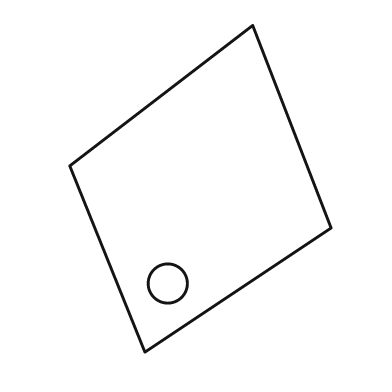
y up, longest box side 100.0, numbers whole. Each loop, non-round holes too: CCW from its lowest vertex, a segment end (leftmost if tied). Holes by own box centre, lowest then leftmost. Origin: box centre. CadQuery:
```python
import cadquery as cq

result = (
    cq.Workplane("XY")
    .moveTo(-17.0, -50.0)
    .lineTo(40.0, -12.0)
    .lineTo(16.0, 50.0)
    .lineTo(-40.0, 7.0)
    .close()
    .moveTo(-10.0, -29.0)
    .circle(6.0)
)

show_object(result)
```